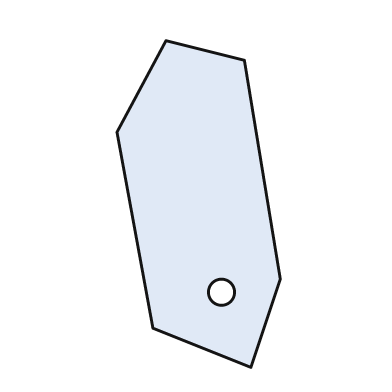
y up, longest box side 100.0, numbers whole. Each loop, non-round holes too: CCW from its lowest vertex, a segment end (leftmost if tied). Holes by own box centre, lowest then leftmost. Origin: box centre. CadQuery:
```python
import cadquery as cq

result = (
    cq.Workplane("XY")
    .moveTo(16.0, -50.0)
    .lineTo(25.0, -23.0)
    .lineTo(14.0, 44.0)
    .lineTo(-10.0, 50.0)
    .lineTo(-25.0, 22.0)
    .lineTo(-14.0, -38.0)
    .close()
    .moveTo(7.0, -27.0)
    .circle(4.0)
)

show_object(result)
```